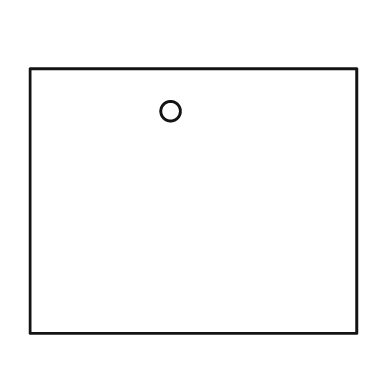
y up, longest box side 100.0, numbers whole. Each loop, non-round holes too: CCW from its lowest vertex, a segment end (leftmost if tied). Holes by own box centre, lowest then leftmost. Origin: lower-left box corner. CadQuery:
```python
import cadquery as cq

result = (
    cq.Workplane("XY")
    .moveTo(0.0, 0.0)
    .lineTo(100.0, 0.0)
    .lineTo(100.0, 81.0)
    .lineTo(0.0, 81.0)
    .close()
    .moveTo(43.0, 68.0)
    .circle(3.0)
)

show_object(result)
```